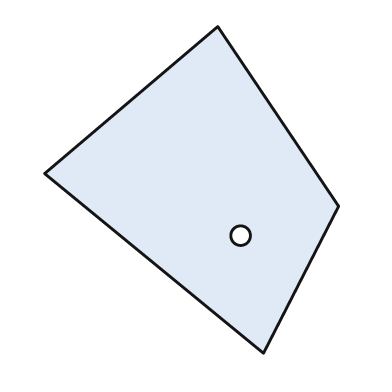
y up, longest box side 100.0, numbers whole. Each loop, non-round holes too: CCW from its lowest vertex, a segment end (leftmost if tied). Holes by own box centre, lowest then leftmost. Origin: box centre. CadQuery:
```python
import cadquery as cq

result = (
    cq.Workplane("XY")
    .moveTo(22.0, -50.0)
    .lineTo(45.0, -5.0)
    .lineTo(8.0, 50.0)
    .lineTo(-45.0, 5.0)
    .close()
    .moveTo(15.0, -14.0)
    .circle(3.0)
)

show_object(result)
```